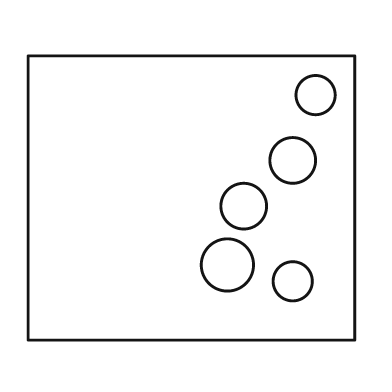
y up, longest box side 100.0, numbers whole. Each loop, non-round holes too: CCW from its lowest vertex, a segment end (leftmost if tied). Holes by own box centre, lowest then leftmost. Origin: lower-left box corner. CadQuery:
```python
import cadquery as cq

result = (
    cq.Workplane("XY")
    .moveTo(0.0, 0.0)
    .lineTo(100.0, 0.0)
    .lineTo(100.0, 87.0)
    .lineTo(0.0, 87.0)
    .close()
    .moveTo(81.0, 18.0)
    .circle(6.0)
    .moveTo(61.0, 23.0)
    .circle(8.0)
    .moveTo(66.0, 41.0)
    .circle(7.0)
    .moveTo(81.0, 55.0)
    .circle(7.0)
    .moveTo(88.0, 75.0)
    .circle(6.0)
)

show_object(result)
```